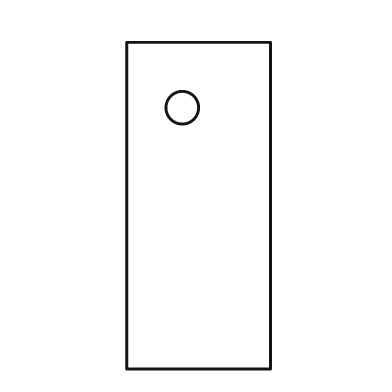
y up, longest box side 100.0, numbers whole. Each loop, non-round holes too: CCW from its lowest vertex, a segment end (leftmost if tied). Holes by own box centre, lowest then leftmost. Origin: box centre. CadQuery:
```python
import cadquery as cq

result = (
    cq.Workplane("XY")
    .moveTo(-22.0, -50.0)
    .lineTo(22.0, -50.0)
    .lineTo(22.0, 50.0)
    .lineTo(-22.0, 50.0)
    .close()
    .moveTo(-5.0, 30.0)
    .circle(5.0)
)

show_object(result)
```